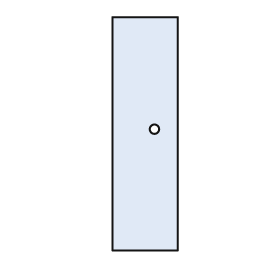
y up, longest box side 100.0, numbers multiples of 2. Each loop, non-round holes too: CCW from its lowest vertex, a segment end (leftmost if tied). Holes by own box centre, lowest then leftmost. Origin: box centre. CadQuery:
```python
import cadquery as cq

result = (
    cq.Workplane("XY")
    .moveTo(-14.0, -50.0)
    .lineTo(14.0, -50.0)
    .lineTo(14.0, 50.0)
    .lineTo(-14.0, 50.0)
    .close()
    .moveTo(4.0, 2.0)
    .circle(2.0)
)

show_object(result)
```